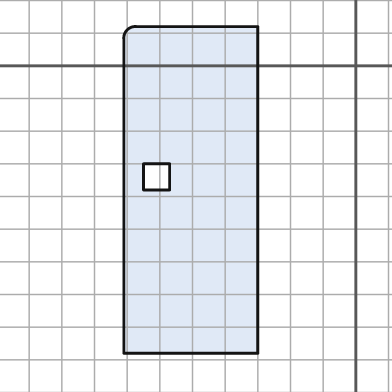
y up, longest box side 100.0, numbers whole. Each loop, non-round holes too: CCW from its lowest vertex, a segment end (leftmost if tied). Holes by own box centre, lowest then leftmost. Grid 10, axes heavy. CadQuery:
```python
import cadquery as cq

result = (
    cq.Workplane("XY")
    .moveTo(-71.0, -88.0)
    .lineTo(-30.0, -88.0)
    .lineTo(-30.0, 12.0)
    .lineTo(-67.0, 12.0)
    .threePointArc((-70.0, 11.0), (-71.0, 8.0))
    .close()
    .moveTo(-65.0, -38.0)
    .lineTo(-57.0, -38.0)
    .lineTo(-57.0, -30.0)
    .lineTo(-65.0, -30.0)
    .close()
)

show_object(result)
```